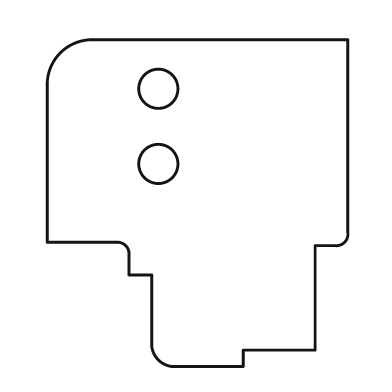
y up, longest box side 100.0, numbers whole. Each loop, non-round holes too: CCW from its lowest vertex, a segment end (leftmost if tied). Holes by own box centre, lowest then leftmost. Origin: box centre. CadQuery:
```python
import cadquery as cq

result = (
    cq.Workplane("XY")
    .moveTo(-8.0, -50.0)
    .lineTo(14.0, -50.0)
    .lineTo(14.0, -45.0)
    .lineTo(36.0, -45.0)
    .lineTo(36.0, -13.0)
    .lineTo(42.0, -13.0)
    .threePointArc((45.0, -12.0), (46.0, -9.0))
    .lineTo(46.0, 50.0)
    .lineTo(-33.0, 50.0)
    .threePointArc((-42.0, 46.0), (-46.0, 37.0))
    .lineTo(-46.0, -12.0)
    .lineTo(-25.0, -12.0)
    .threePointArc((-22.0, -13.0), (-21.0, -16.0))
    .lineTo(-21.0, -22.0)
    .lineTo(-14.0, -22.0)
    .lineTo(-14.0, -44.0)
    .threePointArc((-12.0, -48.0), (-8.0, -50.0))
    .close()
    .moveTo(-12.0, 12.0)
    .circle(6.0)
    .moveTo(-12.0, 35.0)
    .circle(6.0)
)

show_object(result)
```